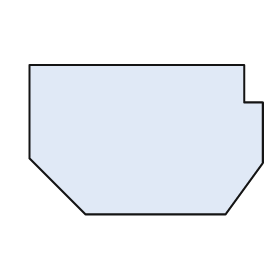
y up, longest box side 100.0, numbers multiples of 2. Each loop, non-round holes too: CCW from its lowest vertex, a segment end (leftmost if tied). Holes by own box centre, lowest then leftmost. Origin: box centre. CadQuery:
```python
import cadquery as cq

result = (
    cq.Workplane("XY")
    .moveTo(-26.0, -32.0)
    .lineTo(34.0, -32.0)
    .lineTo(50.0, -10.0)
    .lineTo(50.0, 16.0)
    .lineTo(42.0, 16.0)
    .lineTo(42.0, 32.0)
    .lineTo(-50.0, 32.0)
    .lineTo(-50.0, -8.0)
    .close()
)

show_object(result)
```